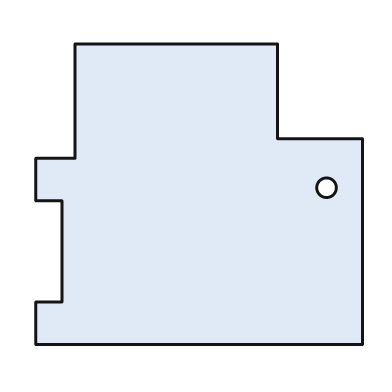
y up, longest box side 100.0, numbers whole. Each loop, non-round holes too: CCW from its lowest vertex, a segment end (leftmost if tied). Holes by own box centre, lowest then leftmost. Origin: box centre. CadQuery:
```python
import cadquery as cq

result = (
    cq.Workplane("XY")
    .moveTo(-50.0, -46.0)
    .lineTo(50.0, -46.0)
    .lineTo(50.0, 17.0)
    .lineTo(24.0, 17.0)
    .lineTo(24.0, 46.0)
    .lineTo(-38.0, 46.0)
    .lineTo(-38.0, 11.0)
    .lineTo(-50.0, 11.0)
    .lineTo(-50.0, -2.0)
    .lineTo(-42.0, -2.0)
    .lineTo(-42.0, -33.0)
    .lineTo(-50.0, -33.0)
    .close()
    .moveTo(39.0, 2.0)
    .circle(3.0)
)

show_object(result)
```